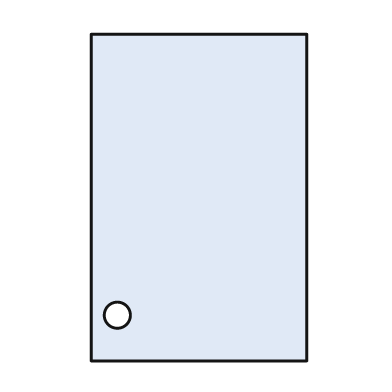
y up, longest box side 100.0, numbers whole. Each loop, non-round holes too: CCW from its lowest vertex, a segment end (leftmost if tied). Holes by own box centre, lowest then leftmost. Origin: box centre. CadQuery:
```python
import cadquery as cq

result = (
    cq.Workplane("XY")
    .moveTo(-33.0, -50.0)
    .lineTo(33.0, -50.0)
    .lineTo(33.0, 50.0)
    .lineTo(-33.0, 50.0)
    .close()
    .moveTo(-25.0, -36.0)
    .circle(4.0)
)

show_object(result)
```